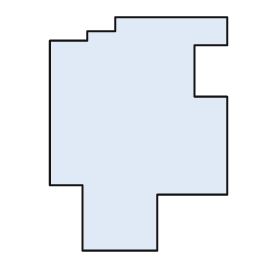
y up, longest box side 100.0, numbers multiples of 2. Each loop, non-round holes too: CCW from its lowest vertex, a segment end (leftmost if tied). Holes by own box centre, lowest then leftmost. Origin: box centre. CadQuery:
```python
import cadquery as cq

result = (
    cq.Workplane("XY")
    .moveTo(-24.0, -50.0)
    .lineTo(8.0, -50.0)
    .lineTo(8.0, -26.0)
    .lineTo(38.0, -26.0)
    .lineTo(38.0, 16.0)
    .lineTo(24.0, 16.0)
    .lineTo(24.0, 38.0)
    .lineTo(38.0, 38.0)
    .lineTo(38.0, 50.0)
    .lineTo(-10.0, 50.0)
    .lineTo(-10.0, 44.0)
    .lineTo(-22.0, 44.0)
    .lineTo(-22.0, 40.0)
    .lineTo(-38.0, 40.0)
    .lineTo(-38.0, -22.0)
    .lineTo(-24.0, -22.0)
    .close()
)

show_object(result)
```